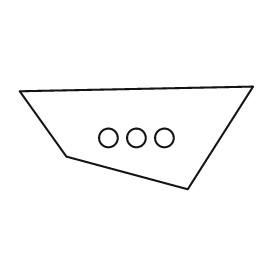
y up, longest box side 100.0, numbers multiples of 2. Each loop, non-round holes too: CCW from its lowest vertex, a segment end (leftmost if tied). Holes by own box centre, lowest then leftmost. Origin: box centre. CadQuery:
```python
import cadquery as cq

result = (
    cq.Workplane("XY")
    .moveTo(22.0, -22.0)
    .lineTo(50.0, 22.0)
    .lineTo(-50.0, 20.0)
    .lineTo(-30.0, -8.0)
    .close()
    .moveTo(-12.0, 0.0)
    .circle(4.0)
    .moveTo(0.0, 0.0)
    .circle(4.0)
    .moveTo(12.0, 0.0)
    .circle(4.0)
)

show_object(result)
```